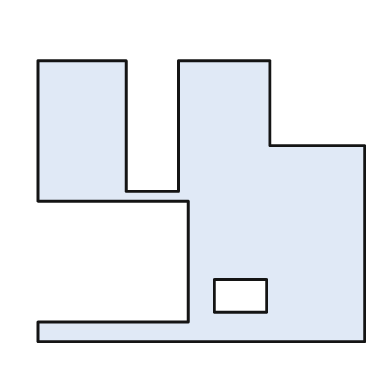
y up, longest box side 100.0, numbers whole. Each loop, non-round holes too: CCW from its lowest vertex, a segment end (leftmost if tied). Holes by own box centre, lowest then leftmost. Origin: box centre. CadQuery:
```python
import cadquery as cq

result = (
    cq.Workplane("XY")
    .moveTo(-50.0, -43.0)
    .lineTo(50.0, -43.0)
    .lineTo(50.0, 17.0)
    .lineTo(21.0, 17.0)
    .lineTo(21.0, 43.0)
    .lineTo(-7.0, 43.0)
    .lineTo(-7.0, 3.0)
    .lineTo(-23.0, 3.0)
    .lineTo(-23.0, 43.0)
    .lineTo(-50.0, 43.0)
    .lineTo(-50.0, 0.0)
    .lineTo(-4.0, 0.0)
    .lineTo(-4.0, -37.0)
    .lineTo(-50.0, -37.0)
    .close()
    .moveTo(4.0, -34.0)
    .lineTo(20.0, -34.0)
    .lineTo(20.0, -24.0)
    .lineTo(4.0, -24.0)
    .close()
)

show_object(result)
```